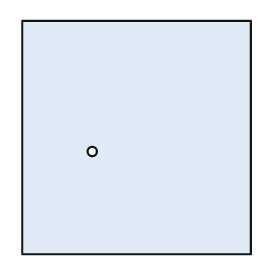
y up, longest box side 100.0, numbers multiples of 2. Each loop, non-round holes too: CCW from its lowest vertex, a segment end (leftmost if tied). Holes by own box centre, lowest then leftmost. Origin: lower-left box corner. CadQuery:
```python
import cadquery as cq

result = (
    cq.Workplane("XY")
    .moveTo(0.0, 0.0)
    .lineTo(98.0, 0.0)
    .lineTo(98.0, 100.0)
    .lineTo(0.0, 100.0)
    .close()
    .moveTo(30.0, 44.0)
    .circle(2.0)
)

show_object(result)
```